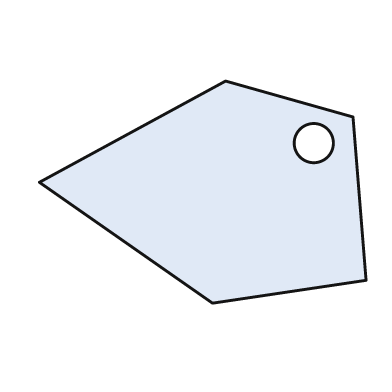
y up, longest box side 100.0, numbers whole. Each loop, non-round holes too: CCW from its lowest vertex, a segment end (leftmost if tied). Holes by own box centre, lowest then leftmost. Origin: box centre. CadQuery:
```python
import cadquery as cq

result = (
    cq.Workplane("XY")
    .moveTo(3.0, -34.0)
    .lineTo(50.0, -27.0)
    .lineTo(46.0, 23.0)
    .lineTo(7.0, 34.0)
    .lineTo(-50.0, 3.0)
    .close()
    .moveTo(34.0, 15.0)
    .circle(6.0)
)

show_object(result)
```